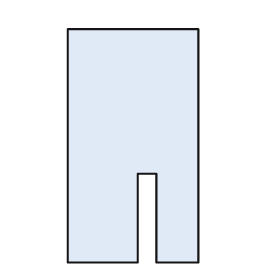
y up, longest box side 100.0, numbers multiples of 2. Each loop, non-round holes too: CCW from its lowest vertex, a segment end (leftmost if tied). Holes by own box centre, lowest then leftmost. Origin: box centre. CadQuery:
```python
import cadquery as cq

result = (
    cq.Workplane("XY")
    .moveTo(-28.0, -50.0)
    .lineTo(2.0, -50.0)
    .lineTo(2.0, -12.0)
    .lineTo(10.0, -12.0)
    .lineTo(10.0, -50.0)
    .lineTo(28.0, -50.0)
    .lineTo(28.0, 50.0)
    .lineTo(-28.0, 50.0)
    .close()
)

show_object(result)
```